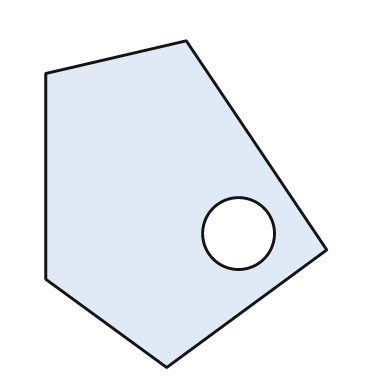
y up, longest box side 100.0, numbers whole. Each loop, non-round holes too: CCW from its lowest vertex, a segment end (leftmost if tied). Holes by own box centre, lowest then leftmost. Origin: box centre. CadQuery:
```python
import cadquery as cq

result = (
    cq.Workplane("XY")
    .moveTo(-6.0, -50.0)
    .lineTo(43.0, -14.0)
    .lineTo(0.0, 50.0)
    .lineTo(-43.0, 40.0)
    .lineTo(-43.0, -23.0)
    .close()
    .moveTo(16.0, -9.0)
    .circle(11.0)
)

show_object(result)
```